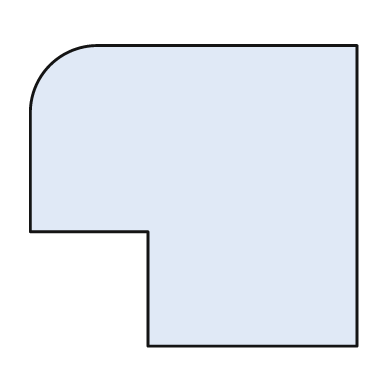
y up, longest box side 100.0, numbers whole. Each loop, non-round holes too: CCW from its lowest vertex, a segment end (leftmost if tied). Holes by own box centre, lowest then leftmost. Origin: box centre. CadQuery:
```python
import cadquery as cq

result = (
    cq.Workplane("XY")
    .moveTo(-14.0, -46.0)
    .lineTo(50.0, -46.0)
    .lineTo(50.0, 46.0)
    .lineTo(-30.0, 46.0)
    .threePointArc((-44.0, 40.0), (-50.0, 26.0))
    .lineTo(-50.0, -11.0)
    .lineTo(-14.0, -11.0)
    .close()
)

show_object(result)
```